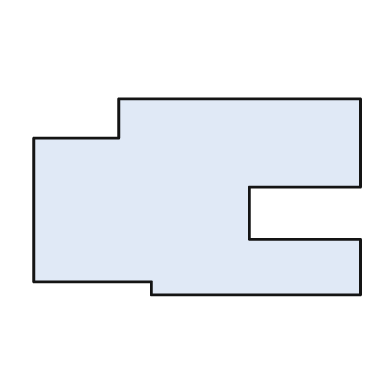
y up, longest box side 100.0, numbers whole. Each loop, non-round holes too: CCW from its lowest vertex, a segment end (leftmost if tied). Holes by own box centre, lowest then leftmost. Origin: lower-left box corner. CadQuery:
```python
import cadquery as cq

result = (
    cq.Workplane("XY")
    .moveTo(36.0, 0.0)
    .lineTo(100.0, 0.0)
    .lineTo(100.0, 17.0)
    .lineTo(66.0, 17.0)
    .lineTo(66.0, 33.0)
    .lineTo(100.0, 33.0)
    .lineTo(100.0, 60.0)
    .lineTo(26.0, 60.0)
    .lineTo(26.0, 48.0)
    .lineTo(0.0, 48.0)
    .lineTo(0.0, 4.0)
    .lineTo(36.0, 4.0)
    .close()
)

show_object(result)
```